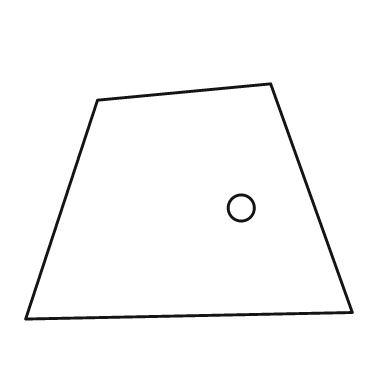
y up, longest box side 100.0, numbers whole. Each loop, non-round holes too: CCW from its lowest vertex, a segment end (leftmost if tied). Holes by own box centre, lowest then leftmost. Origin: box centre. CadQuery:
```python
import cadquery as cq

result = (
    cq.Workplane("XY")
    .moveTo(-50.0, -36.0)
    .lineTo(50.0, -34.0)
    .lineTo(25.0, 36.0)
    .lineTo(-28.0, 31.0)
    .close()
    .moveTo(16.0, -2.0)
    .circle(4.0)
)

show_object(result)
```